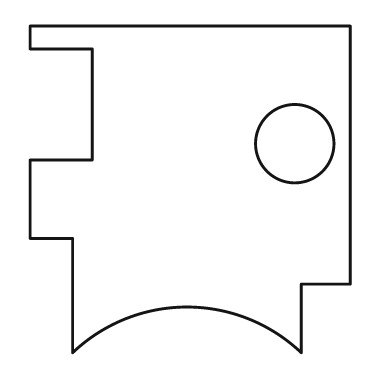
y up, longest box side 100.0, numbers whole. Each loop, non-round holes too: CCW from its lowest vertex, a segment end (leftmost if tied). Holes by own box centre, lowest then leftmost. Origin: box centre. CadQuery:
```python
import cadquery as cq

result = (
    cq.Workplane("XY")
    .moveTo(-36.0, -50.0)
    .threePointArc((-1.0, -36.0), (34.0, -50.0))
    .lineTo(34.0, -29.0)
    .lineTo(49.0, -29.0)
    .lineTo(49.0, 50.0)
    .lineTo(-49.0, 50.0)
    .lineTo(-49.0, 43.0)
    .lineTo(-30.0, 43.0)
    .lineTo(-30.0, 9.0)
    .lineTo(-49.0, 9.0)
    .lineTo(-49.0, -15.0)
    .lineTo(-36.0, -15.0)
    .close()
    .moveTo(32.0, 14.0)
    .circle(12.0)
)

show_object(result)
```